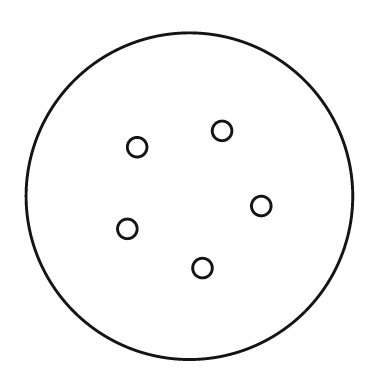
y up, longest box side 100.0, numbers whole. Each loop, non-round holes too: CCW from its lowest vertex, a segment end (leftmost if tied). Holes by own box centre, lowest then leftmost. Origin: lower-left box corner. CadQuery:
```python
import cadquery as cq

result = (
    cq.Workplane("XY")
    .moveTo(50.0, 50.0)
    .circle(50.0)
    .moveTo(54.0, 28.0)
    .circle(3.0)
    .moveTo(31.0, 40.0)
    .circle(3.0)
    .moveTo(72.0, 47.0)
    .circle(3.0)
    .moveTo(34.0, 65.0)
    .circle(3.0)
    .moveTo(60.0, 70.0)
    .circle(3.0)
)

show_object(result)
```